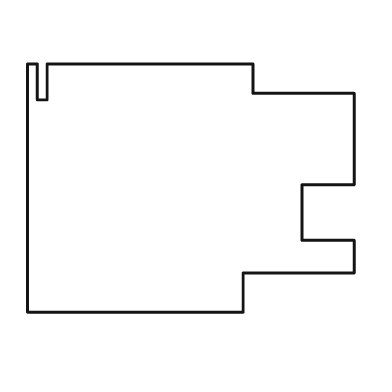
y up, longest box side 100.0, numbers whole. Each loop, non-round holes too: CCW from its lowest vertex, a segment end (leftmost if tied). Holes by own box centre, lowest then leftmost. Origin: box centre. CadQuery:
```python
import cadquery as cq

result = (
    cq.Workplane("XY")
    .moveTo(-50.0, -38.0)
    .lineTo(16.0, -38.0)
    .lineTo(16.0, -26.0)
    .lineTo(50.0, -26.0)
    .lineTo(50.0, -16.0)
    .lineTo(34.0, -16.0)
    .lineTo(34.0, 1.0)
    .lineTo(50.0, 1.0)
    .lineTo(50.0, 29.0)
    .lineTo(19.0, 29.0)
    .lineTo(19.0, 38.0)
    .lineTo(-44.0, 38.0)
    .lineTo(-44.0, 27.0)
    .lineTo(-47.0, 27.0)
    .lineTo(-47.0, 38.0)
    .lineTo(-50.0, 38.0)
    .close()
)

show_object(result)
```